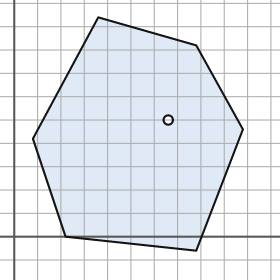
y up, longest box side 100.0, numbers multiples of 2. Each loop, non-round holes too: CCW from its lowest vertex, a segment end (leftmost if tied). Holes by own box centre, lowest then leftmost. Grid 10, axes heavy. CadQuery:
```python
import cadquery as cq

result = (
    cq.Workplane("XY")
    .moveTo(78.0, -6.0)
    .lineTo(98.0, 46.0)
    .lineTo(78.0, 82.0)
    .lineTo(36.0, 94.0)
    .lineTo(8.0, 42.0)
    .lineTo(22.0, 0.0)
    .close()
    .moveTo(66.0, 50.0)
    .circle(2.0)
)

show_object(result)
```